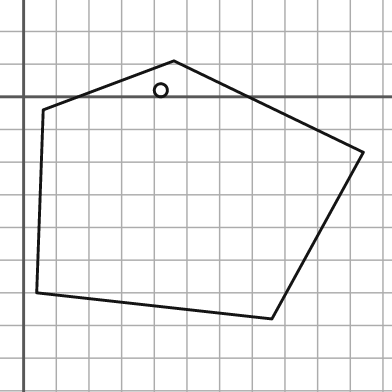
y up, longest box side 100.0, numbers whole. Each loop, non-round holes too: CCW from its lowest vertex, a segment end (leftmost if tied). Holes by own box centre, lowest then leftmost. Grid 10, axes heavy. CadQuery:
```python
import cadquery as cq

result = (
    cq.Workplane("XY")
    .moveTo(76.0, -68.0)
    .lineTo(104.0, -17.0)
    .lineTo(46.0, 11.0)
    .lineTo(6.0, -4.0)
    .lineTo(4.0, -60.0)
    .close()
    .moveTo(42.0, 2.0)
    .circle(2.0)
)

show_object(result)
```